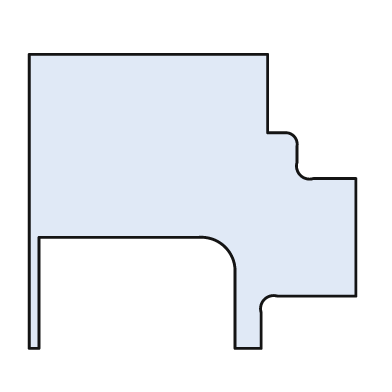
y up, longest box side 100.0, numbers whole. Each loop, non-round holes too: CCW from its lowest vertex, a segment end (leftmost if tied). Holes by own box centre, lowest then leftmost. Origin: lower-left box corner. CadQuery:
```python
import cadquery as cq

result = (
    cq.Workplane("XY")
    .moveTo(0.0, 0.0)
    .lineTo(3.0, 0.0)
    .lineTo(3.0, 34.0)
    .lineTo(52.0, 34.0)
    .threePointArc((60.0, 31.0), (63.0, 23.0))
    .lineTo(63.0, 0.0)
    .lineTo(71.0, 0.0)
    .lineTo(71.0, 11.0)
    .threePointArc((72.0, 15.0), (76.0, 16.0))
    .lineTo(100.0, 16.0)
    .lineTo(100.0, 52.0)
    .lineTo(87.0, 52.0)
    .threePointArc((83.0, 53.0), (82.0, 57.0))
    .lineTo(82.0, 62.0)
    .threePointArc((81.0, 65.0), (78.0, 66.0))
    .lineTo(73.0, 66.0)
    .lineTo(73.0, 90.0)
    .lineTo(0.0, 90.0)
    .close()
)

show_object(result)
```